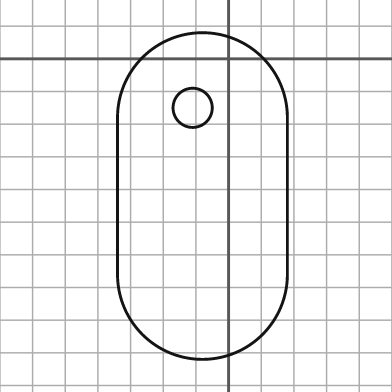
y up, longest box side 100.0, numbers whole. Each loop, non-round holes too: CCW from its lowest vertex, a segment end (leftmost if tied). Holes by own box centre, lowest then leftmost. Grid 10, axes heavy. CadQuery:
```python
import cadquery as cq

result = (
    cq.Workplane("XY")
    .moveTo(-34.0, -66.0)
    .threePointArc((-8.0, -92.0), (18.0, -66.0))
    .lineTo(18.0, -18.0)
    .threePointArc((-8.0, 8.0), (-34.0, -18.0))
    .close()
    .moveTo(-11.0, -15.0)
    .circle(6.0)
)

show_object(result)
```